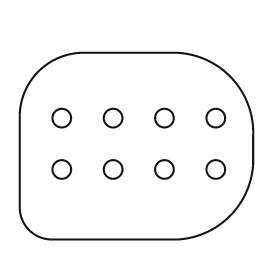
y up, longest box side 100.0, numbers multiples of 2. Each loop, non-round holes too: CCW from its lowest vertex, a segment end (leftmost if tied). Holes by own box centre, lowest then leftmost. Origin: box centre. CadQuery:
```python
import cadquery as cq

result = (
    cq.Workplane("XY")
    .moveTo(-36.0, -40.0)
    .lineTo(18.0, -40.0)
    .threePointArc((40.0, -30.0), (50.0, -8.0))
    .lineTo(50.0, 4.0)
    .threePointArc((40.0, 30.0), (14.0, 40.0))
    .lineTo(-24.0, 40.0)
    .threePointArc((-42.0, 32.0), (-50.0, 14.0))
    .lineTo(-50.0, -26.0)
    .threePointArc((-46.0, -36.0), (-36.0, -40.0))
    .close()
    .moveTo(-32.0, -10.0)
    .circle(4.0)
    .moveTo(-10.0, -10.0)
    .circle(4.0)
    .moveTo(12.0, -10.0)
    .circle(4.0)
    .moveTo(34.0, -10.0)
    .circle(4.0)
    .moveTo(-32.0, 12.0)
    .circle(4.0)
    .moveTo(-10.0, 12.0)
    .circle(4.0)
    .moveTo(12.0, 12.0)
    .circle(4.0)
    .moveTo(34.0, 12.0)
    .circle(4.0)
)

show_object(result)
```